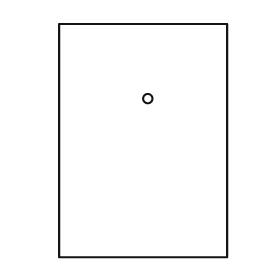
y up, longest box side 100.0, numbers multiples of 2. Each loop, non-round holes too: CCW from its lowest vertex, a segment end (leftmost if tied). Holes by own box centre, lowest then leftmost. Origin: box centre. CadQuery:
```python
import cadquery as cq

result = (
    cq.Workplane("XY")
    .moveTo(-36.0, -50.0)
    .lineTo(36.0, -50.0)
    .lineTo(36.0, 50.0)
    .lineTo(-36.0, 50.0)
    .close()
    .moveTo(2.0, 18.0)
    .circle(2.0)
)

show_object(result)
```